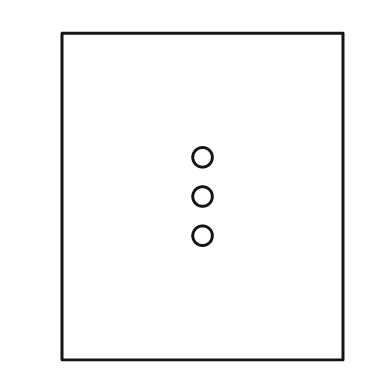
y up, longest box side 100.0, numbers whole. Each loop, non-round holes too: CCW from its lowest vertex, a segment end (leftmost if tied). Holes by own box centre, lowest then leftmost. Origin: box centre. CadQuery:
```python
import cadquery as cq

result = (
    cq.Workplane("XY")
    .moveTo(-43.0, -50.0)
    .lineTo(43.0, -50.0)
    .lineTo(43.0, 50.0)
    .lineTo(-43.0, 50.0)
    .close()
    .moveTo(0.0, -12.0)
    .circle(3.0)
    .moveTo(0.0, 0.0)
    .circle(3.0)
    .moveTo(0.0, 12.0)
    .circle(3.0)
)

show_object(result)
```